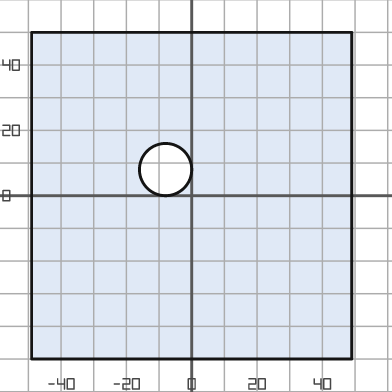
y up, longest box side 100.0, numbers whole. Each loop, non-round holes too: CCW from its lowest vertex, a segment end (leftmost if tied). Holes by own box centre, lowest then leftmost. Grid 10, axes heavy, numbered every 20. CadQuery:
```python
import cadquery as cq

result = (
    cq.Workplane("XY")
    .moveTo(-49.0, -50.0)
    .lineTo(49.0, -50.0)
    .lineTo(49.0, 50.0)
    .lineTo(-49.0, 50.0)
    .close()
    .moveTo(-8.0, 8.0)
    .circle(8.0)
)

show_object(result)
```